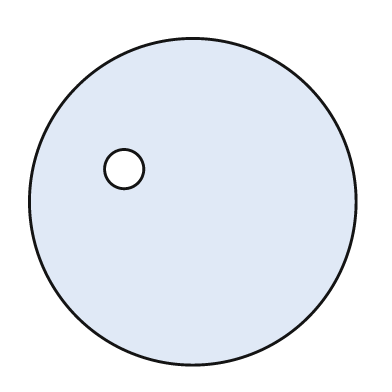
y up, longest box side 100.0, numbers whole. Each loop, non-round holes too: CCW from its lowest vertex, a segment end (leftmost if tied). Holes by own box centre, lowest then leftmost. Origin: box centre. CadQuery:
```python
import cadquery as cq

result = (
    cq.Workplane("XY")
    .moveTo(0.0, 0.0)
    .circle(50.0)
    .moveTo(-21.0, 10.0)
    .circle(6.0)
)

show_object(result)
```